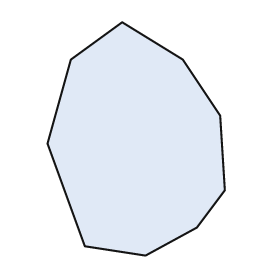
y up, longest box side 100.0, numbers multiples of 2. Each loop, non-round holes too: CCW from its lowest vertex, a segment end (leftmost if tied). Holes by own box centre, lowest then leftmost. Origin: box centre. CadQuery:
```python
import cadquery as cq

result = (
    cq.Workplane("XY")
    .moveTo(4.0, -50.0)
    .lineTo(26.0, -38.0)
    .lineTo(38.0, -22.0)
    .lineTo(36.0, 10.0)
    .lineTo(20.0, 34.0)
    .lineTo(-6.0, 50.0)
    .lineTo(-28.0, 34.0)
    .lineTo(-38.0, -2.0)
    .lineTo(-22.0, -46.0)
    .close()
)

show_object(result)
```